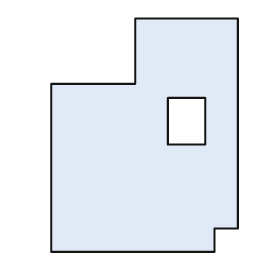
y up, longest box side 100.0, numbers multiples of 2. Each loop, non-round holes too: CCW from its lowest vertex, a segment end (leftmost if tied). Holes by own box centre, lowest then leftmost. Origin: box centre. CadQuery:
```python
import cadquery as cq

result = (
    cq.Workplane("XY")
    .moveTo(-40.0, -50.0)
    .lineTo(30.0, -50.0)
    .lineTo(30.0, -40.0)
    .lineTo(40.0, -40.0)
    .lineTo(40.0, 50.0)
    .lineTo(-4.0, 50.0)
    .lineTo(-4.0, 22.0)
    .lineTo(-40.0, 22.0)
    .close()
    .moveTo(10.0, -4.0)
    .lineTo(26.0, -4.0)
    .lineTo(26.0, 16.0)
    .lineTo(10.0, 16.0)
    .close()
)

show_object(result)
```